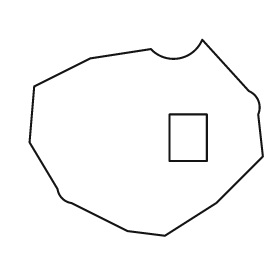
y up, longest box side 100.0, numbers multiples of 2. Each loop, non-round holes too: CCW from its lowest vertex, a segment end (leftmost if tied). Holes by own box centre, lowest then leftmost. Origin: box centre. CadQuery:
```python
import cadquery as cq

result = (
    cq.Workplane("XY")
    .moveTo(8.0, -42.0)
    .lineTo(30.0, -28.0)
    .lineTo(50.0, -8.0)
    .lineTo(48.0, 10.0)
    .threePointArc((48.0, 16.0), (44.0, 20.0))
    .lineTo(24.0, 42.0)
    .threePointArc((14.0, 34.0), (2.0, 38.0))
    .lineTo(-24.0, 34.0)
    .lineTo(-48.0, 22.0)
    .lineTo(-50.0, -2.0)
    .lineTo(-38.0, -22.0)
    .threePointArc((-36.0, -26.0), (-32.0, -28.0))
    .lineTo(-8.0, -40.0)
    .close()
    .moveTo(10.0, -10.0)
    .lineTo(26.0, -10.0)
    .lineTo(26.0, 10.0)
    .lineTo(10.0, 10.0)
    .close()
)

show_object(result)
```